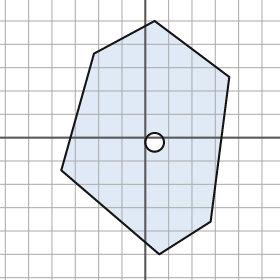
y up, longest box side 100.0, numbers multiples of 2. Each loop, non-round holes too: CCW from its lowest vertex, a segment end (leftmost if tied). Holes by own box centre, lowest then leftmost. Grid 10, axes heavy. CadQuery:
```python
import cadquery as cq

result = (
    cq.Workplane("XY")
    .moveTo(6.0, -50.0)
    .lineTo(28.0, -36.0)
    .lineTo(36.0, 26.0)
    .lineTo(4.0, 50.0)
    .lineTo(-22.0, 36.0)
    .lineTo(-36.0, -14.0)
    .close()
    .moveTo(4.0, -2.0)
    .circle(4.0)
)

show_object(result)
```